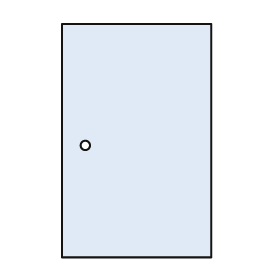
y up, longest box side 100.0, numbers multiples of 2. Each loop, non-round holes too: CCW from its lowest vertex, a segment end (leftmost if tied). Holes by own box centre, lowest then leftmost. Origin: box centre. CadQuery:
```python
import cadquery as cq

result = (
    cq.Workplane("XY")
    .moveTo(-32.0, -50.0)
    .lineTo(32.0, -50.0)
    .lineTo(32.0, 50.0)
    .lineTo(-32.0, 50.0)
    .close()
    .moveTo(-22.0, -2.0)
    .circle(2.0)
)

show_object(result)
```